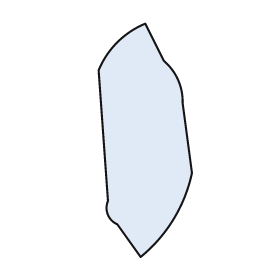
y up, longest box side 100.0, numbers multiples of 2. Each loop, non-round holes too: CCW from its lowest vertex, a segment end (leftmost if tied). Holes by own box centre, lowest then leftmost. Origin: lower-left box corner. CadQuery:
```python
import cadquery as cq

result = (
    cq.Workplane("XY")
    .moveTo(18.0, 0.0)
    .threePointArc((32.0, 16.0), (40.0, 36.0))
    .lineTo(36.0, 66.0)
    .threePointArc((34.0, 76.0), (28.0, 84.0))
    .lineTo(20.0, 100.0)
    .threePointArc((8.0, 92.0), (0.0, 80.0))
    .lineTo(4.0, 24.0)
    .threePointArc((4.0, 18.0), (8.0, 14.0))
    .close()
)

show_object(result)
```